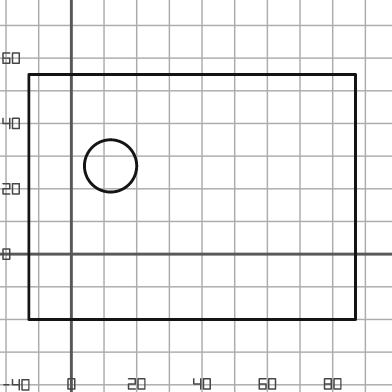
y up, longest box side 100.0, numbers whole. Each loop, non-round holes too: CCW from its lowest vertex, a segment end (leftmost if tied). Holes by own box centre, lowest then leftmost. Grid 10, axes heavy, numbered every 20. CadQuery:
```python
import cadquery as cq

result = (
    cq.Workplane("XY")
    .moveTo(-13.0, -20.0)
    .lineTo(87.0, -20.0)
    .lineTo(87.0, 55.0)
    .lineTo(-13.0, 55.0)
    .close()
    .moveTo(12.0, 27.0)
    .circle(8.0)
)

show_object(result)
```